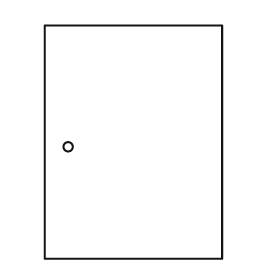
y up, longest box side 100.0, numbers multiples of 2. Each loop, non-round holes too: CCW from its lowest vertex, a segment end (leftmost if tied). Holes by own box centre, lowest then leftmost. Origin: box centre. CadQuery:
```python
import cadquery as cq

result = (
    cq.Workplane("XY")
    .moveTo(-38.0, -50.0)
    .lineTo(38.0, -50.0)
    .lineTo(38.0, 50.0)
    .lineTo(-38.0, 50.0)
    .close()
    .moveTo(-28.0, -2.0)
    .circle(2.0)
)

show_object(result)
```